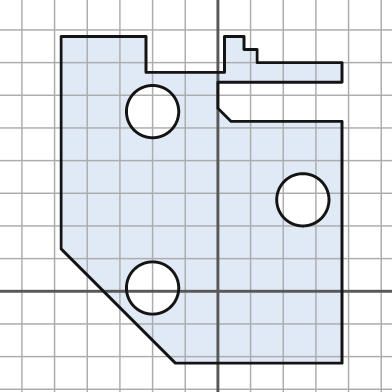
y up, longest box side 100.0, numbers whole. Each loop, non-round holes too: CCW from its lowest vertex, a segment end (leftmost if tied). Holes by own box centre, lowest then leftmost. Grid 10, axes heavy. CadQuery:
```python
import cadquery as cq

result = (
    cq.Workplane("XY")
    .moveTo(-13.0, -22.0)
    .lineTo(38.0, -22.0)
    .lineTo(38.0, 52.0)
    .lineTo(4.0, 52.0)
    .lineTo(0.0, 56.0)
    .lineTo(0.0, 64.0)
    .lineTo(38.0, 64.0)
    .lineTo(38.0, 70.0)
    .lineTo(12.0, 70.0)
    .lineTo(12.0, 74.0)
    .lineTo(8.0, 74.0)
    .lineTo(8.0, 78.0)
    .lineTo(2.0, 78.0)
    .lineTo(2.0, 67.0)
    .lineTo(-22.0, 67.0)
    .lineTo(-22.0, 78.0)
    .lineTo(-48.0, 78.0)
    .lineTo(-48.0, 13.0)
    .close()
    .moveTo(-20.0, 1.0)
    .circle(8.0)
    .moveTo(26.0, 28.0)
    .circle(8.0)
    .moveTo(-20.0, 55.0)
    .circle(8.0)
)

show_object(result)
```